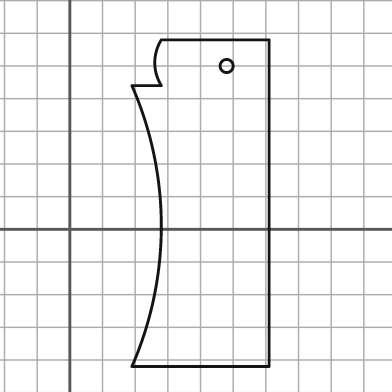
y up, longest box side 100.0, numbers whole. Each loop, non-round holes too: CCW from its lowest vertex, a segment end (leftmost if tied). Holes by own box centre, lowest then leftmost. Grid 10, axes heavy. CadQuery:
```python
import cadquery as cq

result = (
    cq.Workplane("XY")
    .moveTo(19.0, -42.0)
    .lineTo(61.0, -42.0)
    .lineTo(61.0, 58.0)
    .lineTo(28.0, 58.0)
    .threePointArc((26.0, 51.0), (28.0, 44.0))
    .lineTo(19.0, 44.0)
    .threePointArc((28.0, 1.0), (19.0, -42.0))
    .close()
    .moveTo(48.0, 50.0)
    .circle(2.0)
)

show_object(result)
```